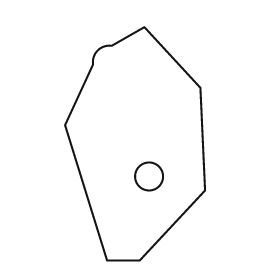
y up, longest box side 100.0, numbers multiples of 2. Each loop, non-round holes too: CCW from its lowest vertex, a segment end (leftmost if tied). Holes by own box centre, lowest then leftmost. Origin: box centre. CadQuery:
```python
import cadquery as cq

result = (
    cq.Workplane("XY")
    .moveTo(-12.0, -50.0)
    .lineTo(2.0, -50.0)
    .lineTo(30.0, -20.0)
    .lineTo(28.0, 24.0)
    .lineTo(4.0, 50.0)
    .lineTo(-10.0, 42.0)
    .threePointArc((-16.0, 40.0), (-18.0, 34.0))
    .lineTo(-30.0, 8.0)
    .close()
    .moveTo(6.0, -14.0)
    .circle(6.0)
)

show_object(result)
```